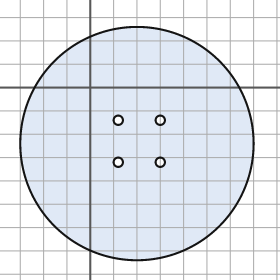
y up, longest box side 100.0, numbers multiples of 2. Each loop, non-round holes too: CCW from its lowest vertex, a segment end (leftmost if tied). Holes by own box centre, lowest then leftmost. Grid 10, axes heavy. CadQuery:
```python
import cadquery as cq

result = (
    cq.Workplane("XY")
    .moveTo(20.0, -24.0)
    .circle(50.0)
    .moveTo(12.0, -32.0)
    .circle(2.0)
    .moveTo(30.0, -32.0)
    .circle(2.0)
    .moveTo(12.0, -14.0)
    .circle(2.0)
    .moveTo(30.0, -14.0)
    .circle(2.0)
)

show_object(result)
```